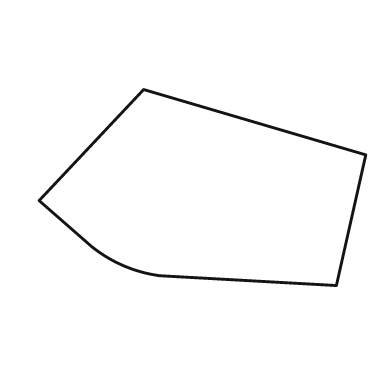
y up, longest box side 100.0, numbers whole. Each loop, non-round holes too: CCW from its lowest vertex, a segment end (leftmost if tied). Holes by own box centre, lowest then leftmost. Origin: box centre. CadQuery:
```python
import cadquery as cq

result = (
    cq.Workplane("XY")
    .moveTo(41.0, -30.0)
    .lineTo(50.0, 10.0)
    .lineTo(-18.0, 30.0)
    .lineTo(-50.0, -4.0)
    .lineTo(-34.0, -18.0)
    .threePointArc((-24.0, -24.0), (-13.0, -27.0))
    .close()
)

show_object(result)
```